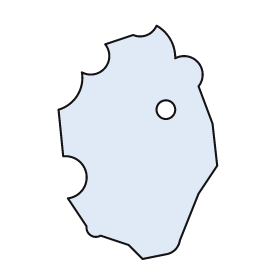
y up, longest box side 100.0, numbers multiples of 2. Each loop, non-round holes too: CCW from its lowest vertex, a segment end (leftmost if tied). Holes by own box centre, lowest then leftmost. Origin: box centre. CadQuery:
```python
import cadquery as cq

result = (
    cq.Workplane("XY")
    .moveTo(2.0, -50.0)
    .lineTo(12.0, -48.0)
    .threePointArc((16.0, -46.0), (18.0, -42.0))
    .lineTo(26.0, -22.0)
    .lineTo(34.0, -10.0)
    .lineTo(32.0, 8.0)
    .lineTo(26.0, 24.0)
    .threePointArc((26.0, 34.0), (16.0, 36.0))
    .threePointArc((14.0, 44.0), (8.0, 50.0))
    .threePointArc((4.0, 46.0), (-2.0, 46.0))
    .lineTo(-14.0, 42.0)
    .threePointArc((-14.0, 32.0), (-24.0, 30.0))
    .threePointArc((-26.0, 20.0), (-34.0, 14.0))
    .lineTo(-32.0, -6.0)
    .threePointArc((-22.0, -14.0), (-30.0, -24.0))
    .lineTo(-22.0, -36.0)
    .threePointArc((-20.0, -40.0), (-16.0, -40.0))
    .lineTo(-4.0, -44.0)
    .close()
    .moveTo(12.0, 14.0)
    .circle(4.0)
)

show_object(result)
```